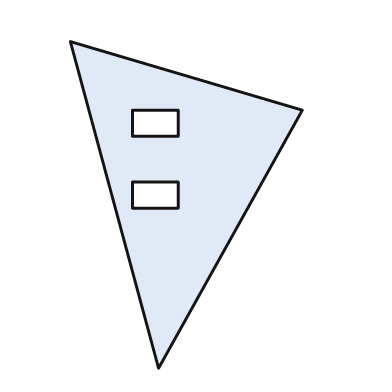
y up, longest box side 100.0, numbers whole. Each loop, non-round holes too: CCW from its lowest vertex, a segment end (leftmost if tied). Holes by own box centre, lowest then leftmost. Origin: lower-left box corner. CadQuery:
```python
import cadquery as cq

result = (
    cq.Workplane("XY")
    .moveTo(27.0, 0.0)
    .lineTo(71.0, 79.0)
    .lineTo(0.0, 100.0)
    .close()
    .moveTo(19.0, 49.0)
    .lineTo(33.0, 49.0)
    .lineTo(33.0, 57.0)
    .lineTo(19.0, 57.0)
    .close()
    .moveTo(19.0, 71.0)
    .lineTo(33.0, 71.0)
    .lineTo(33.0, 79.0)
    .lineTo(19.0, 79.0)
    .close()
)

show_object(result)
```